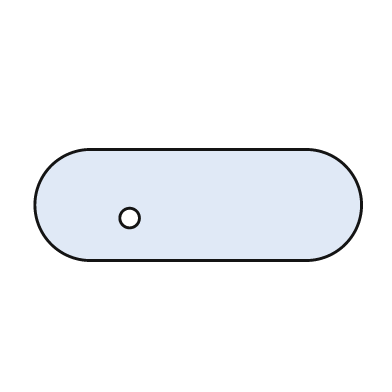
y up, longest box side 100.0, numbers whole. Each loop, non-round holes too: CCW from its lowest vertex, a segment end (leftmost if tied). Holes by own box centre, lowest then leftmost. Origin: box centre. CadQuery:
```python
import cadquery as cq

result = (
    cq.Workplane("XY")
    .moveTo(-33.0, -17.0)
    .lineTo(33.0, -17.0)
    .threePointArc((50.0, 0.0), (33.0, 17.0))
    .lineTo(-33.0, 17.0)
    .threePointArc((-50.0, 0.0), (-33.0, -17.0))
    .close()
    .moveTo(-21.0, -4.0)
    .circle(3.0)
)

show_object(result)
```